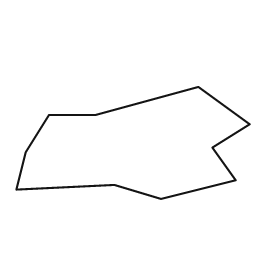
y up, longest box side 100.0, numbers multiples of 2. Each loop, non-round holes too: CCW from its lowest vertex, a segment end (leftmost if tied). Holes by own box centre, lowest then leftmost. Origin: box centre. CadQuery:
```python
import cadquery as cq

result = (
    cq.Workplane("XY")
    .moveTo(12.0, -24.0)
    .lineTo(44.0, -16.0)
    .lineTo(34.0, -2.0)
    .lineTo(50.0, 8.0)
    .lineTo(28.0, 24.0)
    .lineTo(-16.0, 12.0)
    .lineTo(-36.0, 12.0)
    .lineTo(-46.0, -4.0)
    .lineTo(-50.0, -20.0)
    .lineTo(-8.0, -18.0)
    .close()
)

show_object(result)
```